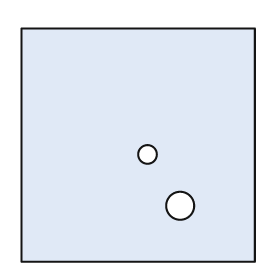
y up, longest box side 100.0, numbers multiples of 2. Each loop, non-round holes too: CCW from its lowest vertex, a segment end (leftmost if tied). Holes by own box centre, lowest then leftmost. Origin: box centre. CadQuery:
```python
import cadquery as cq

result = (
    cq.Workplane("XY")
    .moveTo(-50.0, -50.0)
    .lineTo(50.0, -50.0)
    .lineTo(50.0, 50.0)
    .lineTo(-50.0, 50.0)
    .close()
    .moveTo(18.0, -26.0)
    .circle(6.0)
    .moveTo(4.0, -4.0)
    .circle(4.0)
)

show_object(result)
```